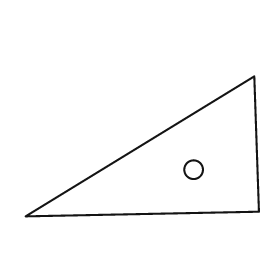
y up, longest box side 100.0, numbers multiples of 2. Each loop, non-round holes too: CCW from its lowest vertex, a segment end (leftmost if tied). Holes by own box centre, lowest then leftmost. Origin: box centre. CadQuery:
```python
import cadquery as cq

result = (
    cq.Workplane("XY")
    .moveTo(-50.0, -30.0)
    .lineTo(50.0, -28.0)
    .lineTo(48.0, 30.0)
    .close()
    .moveTo(22.0, -10.0)
    .circle(4.0)
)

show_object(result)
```